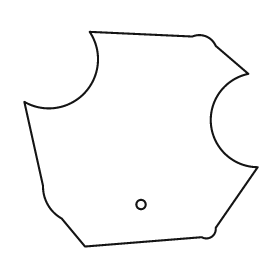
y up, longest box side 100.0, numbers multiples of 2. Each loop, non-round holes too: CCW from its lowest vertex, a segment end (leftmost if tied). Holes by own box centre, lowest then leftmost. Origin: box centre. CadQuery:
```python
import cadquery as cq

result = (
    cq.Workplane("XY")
    .moveTo(-24.0, -46.0)
    .lineTo(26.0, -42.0)
    .threePointArc((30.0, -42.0), (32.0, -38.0))
    .lineTo(50.0, -12.0)
    .threePointArc((30.0, 6.0), (46.0, 28.0))
    .lineTo(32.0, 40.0)
    .threePointArc((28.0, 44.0), (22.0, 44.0))
    .lineTo(-22.0, 46.0)
    .threePointArc((-24.0, 20.0), (-50.0, 16.0))
    .lineTo(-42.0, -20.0)
    .threePointArc((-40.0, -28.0), (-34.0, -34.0))
    .close()
    .moveTo(0.0, -28.0)
    .circle(2.0)
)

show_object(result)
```